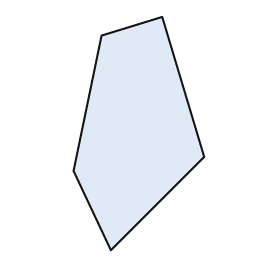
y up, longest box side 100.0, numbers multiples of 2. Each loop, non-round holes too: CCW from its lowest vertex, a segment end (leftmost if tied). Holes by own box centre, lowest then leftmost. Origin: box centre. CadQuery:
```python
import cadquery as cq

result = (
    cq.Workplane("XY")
    .moveTo(-12.0, -50.0)
    .lineTo(28.0, -10.0)
    .lineTo(10.0, 50.0)
    .lineTo(-16.0, 42.0)
    .lineTo(-28.0, -16.0)
    .close()
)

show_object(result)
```